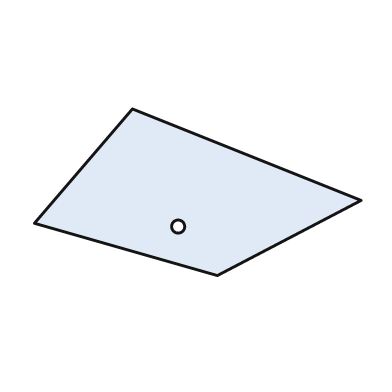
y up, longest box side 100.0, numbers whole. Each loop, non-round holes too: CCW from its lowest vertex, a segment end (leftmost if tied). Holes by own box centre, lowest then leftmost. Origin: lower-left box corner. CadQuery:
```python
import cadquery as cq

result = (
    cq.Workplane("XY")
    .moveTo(56.0, 0.0)
    .lineTo(100.0, 23.0)
    .lineTo(30.0, 51.0)
    .lineTo(0.0, 16.0)
    .close()
    .moveTo(44.0, 15.0)
    .circle(2.0)
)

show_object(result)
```